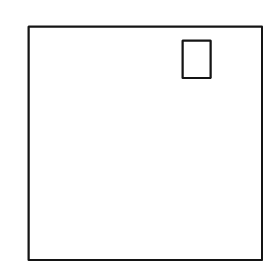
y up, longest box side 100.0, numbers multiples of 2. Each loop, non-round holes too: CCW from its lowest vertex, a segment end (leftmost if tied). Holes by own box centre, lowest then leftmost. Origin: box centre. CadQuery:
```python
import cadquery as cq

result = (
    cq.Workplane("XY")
    .moveTo(-50.0, -50.0)
    .lineTo(50.0, -50.0)
    .lineTo(50.0, 50.0)
    .lineTo(-50.0, 50.0)
    .close()
    .moveTo(16.0, 28.0)
    .lineTo(28.0, 28.0)
    .lineTo(28.0, 44.0)
    .lineTo(16.0, 44.0)
    .close()
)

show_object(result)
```